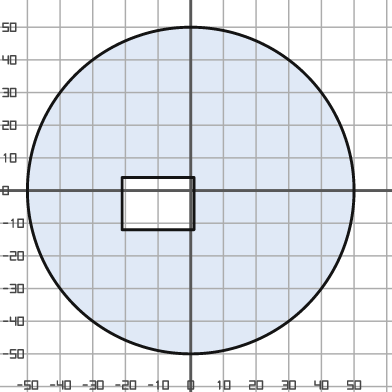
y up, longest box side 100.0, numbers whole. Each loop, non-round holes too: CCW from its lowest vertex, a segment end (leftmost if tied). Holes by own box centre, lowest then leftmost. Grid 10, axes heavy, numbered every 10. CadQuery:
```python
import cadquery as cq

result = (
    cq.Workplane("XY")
    .moveTo(0.0, 0.0)
    .circle(50.0)
    .moveTo(-21.0, -12.0)
    .lineTo(1.0, -12.0)
    .lineTo(1.0, 4.0)
    .lineTo(-21.0, 4.0)
    .close()
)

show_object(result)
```